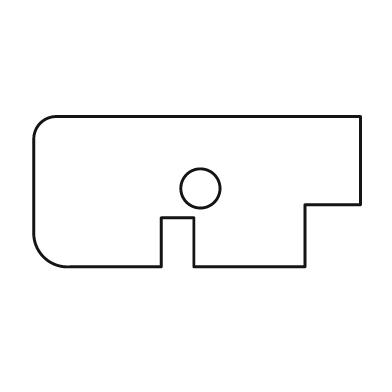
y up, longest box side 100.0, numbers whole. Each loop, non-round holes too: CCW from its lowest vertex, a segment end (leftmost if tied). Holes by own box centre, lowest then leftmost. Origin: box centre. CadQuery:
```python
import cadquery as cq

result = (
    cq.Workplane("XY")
    .moveTo(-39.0, -23.0)
    .lineTo(-11.0, -23.0)
    .lineTo(-11.0, -8.0)
    .lineTo(-1.0, -8.0)
    .lineTo(-1.0, -23.0)
    .lineTo(33.0, -23.0)
    .lineTo(33.0, -4.0)
    .lineTo(50.0, -4.0)
    .lineTo(50.0, 23.0)
    .lineTo(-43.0, 23.0)
    .threePointArc((-48.0, 21.0), (-50.0, 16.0))
    .lineTo(-50.0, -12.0)
    .threePointArc((-47.0, -20.0), (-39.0, -23.0))
    .close()
    .moveTo(1.0, 1.0)
    .circle(6.0)
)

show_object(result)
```